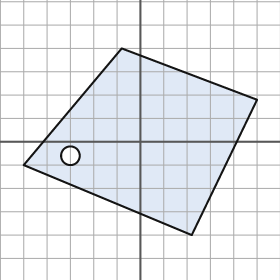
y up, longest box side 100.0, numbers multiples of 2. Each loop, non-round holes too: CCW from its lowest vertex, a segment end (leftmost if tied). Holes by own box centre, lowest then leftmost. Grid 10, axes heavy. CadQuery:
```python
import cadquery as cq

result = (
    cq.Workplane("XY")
    .moveTo(22.0, -40.0)
    .lineTo(50.0, 18.0)
    .lineTo(-8.0, 40.0)
    .lineTo(-50.0, -10.0)
    .close()
    .moveTo(-30.0, -6.0)
    .circle(4.0)
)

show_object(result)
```